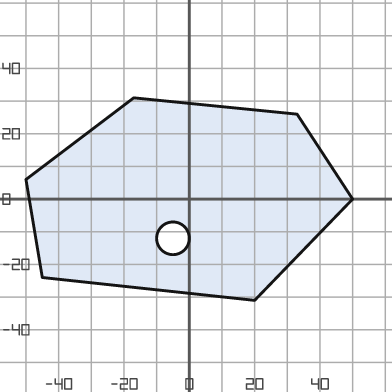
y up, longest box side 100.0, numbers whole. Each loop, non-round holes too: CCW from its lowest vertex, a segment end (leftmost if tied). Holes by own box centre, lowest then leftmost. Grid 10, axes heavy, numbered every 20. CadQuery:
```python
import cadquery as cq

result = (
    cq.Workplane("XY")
    .moveTo(20.0, -31.0)
    .lineTo(50.0, 0.0)
    .lineTo(33.0, 26.0)
    .lineTo(-17.0, 31.0)
    .lineTo(-50.0, 6.0)
    .lineTo(-45.0, -24.0)
    .close()
    .moveTo(-5.0, -12.0)
    .circle(5.0)
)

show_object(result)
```